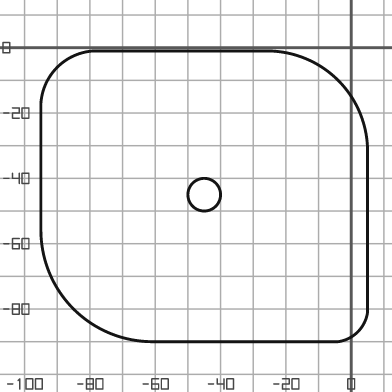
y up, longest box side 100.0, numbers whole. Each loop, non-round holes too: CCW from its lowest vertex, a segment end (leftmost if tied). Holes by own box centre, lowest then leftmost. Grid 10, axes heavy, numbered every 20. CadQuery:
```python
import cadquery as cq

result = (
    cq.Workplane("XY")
    .moveTo(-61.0, -90.0)
    .lineTo(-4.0, -90.0)
    .threePointArc((2.0, -87.0), (5.0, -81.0))
    .lineTo(5.0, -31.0)
    .threePointArc((-4.0, -10.0), (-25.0, -1.0))
    .lineTo(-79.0, -1.0)
    .threePointArc((-90.0, -6.0), (-95.0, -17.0))
    .lineTo(-95.0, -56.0)
    .threePointArc((-85.0, -80.0), (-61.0, -90.0))
    .close()
    .moveTo(-45.0, -45.0)
    .circle(5.0)
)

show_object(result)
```